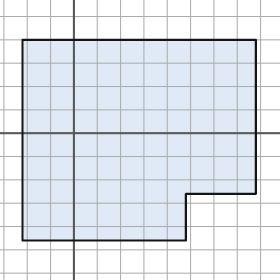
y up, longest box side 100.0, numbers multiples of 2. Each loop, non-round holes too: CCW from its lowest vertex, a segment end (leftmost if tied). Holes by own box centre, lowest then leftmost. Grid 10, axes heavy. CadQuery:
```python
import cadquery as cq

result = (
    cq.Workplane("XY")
    .moveTo(-22.0, -46.0)
    .lineTo(48.0, -46.0)
    .lineTo(48.0, -26.0)
    .lineTo(78.0, -26.0)
    .lineTo(78.0, 40.0)
    .lineTo(-22.0, 40.0)
    .close()
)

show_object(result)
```